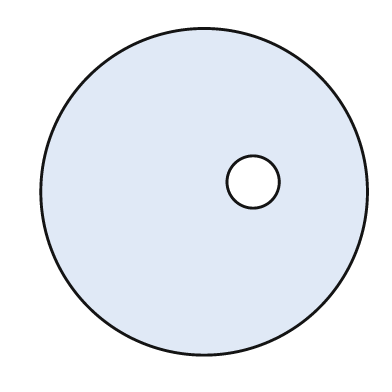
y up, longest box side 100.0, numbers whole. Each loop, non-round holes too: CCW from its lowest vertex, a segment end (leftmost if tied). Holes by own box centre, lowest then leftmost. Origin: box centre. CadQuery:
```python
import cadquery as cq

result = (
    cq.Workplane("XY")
    .moveTo(0.0, 0.0)
    .circle(50.0)
    .moveTo(15.0, 3.0)
    .circle(8.0)
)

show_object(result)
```